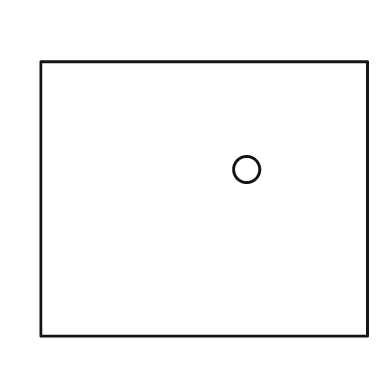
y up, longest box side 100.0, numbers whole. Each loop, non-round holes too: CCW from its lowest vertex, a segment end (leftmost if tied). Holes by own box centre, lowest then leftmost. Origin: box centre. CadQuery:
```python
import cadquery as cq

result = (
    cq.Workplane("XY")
    .moveTo(-50.0, -42.0)
    .lineTo(50.0, -42.0)
    .lineTo(50.0, 42.0)
    .lineTo(-50.0, 42.0)
    .close()
    .moveTo(13.0, 9.0)
    .circle(4.0)
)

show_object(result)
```